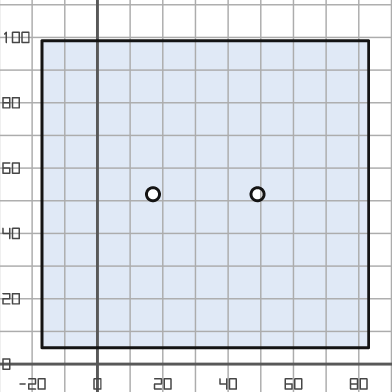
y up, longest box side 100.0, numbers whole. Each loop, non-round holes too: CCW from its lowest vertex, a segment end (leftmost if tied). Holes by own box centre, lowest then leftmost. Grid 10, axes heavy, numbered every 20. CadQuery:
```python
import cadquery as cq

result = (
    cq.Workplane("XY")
    .moveTo(-17.0, 5.0)
    .lineTo(83.0, 5.0)
    .lineTo(83.0, 99.0)
    .lineTo(-17.0, 99.0)
    .close()
    .moveTo(17.0, 52.0)
    .circle(2.0)
    .moveTo(49.0, 52.0)
    .circle(2.0)
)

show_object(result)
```